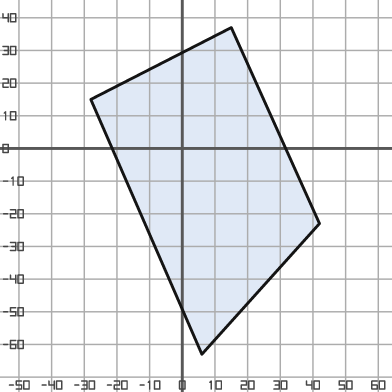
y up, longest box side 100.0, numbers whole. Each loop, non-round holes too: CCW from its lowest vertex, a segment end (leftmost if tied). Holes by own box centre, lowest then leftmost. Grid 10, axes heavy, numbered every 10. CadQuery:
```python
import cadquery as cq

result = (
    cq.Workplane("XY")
    .moveTo(6.0, -63.0)
    .lineTo(42.0, -23.0)
    .lineTo(15.0, 37.0)
    .lineTo(-28.0, 15.0)
    .close()
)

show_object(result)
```